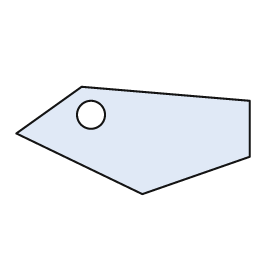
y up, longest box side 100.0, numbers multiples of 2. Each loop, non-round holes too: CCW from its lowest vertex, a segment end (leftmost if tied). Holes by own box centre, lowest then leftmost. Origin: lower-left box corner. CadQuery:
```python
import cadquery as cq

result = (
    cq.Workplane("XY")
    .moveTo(54.0, 0.0)
    .lineTo(100.0, 16.0)
    .lineTo(100.0, 40.0)
    .lineTo(28.0, 46.0)
    .lineTo(0.0, 26.0)
    .close()
    .moveTo(32.0, 34.0)
    .circle(6.0)
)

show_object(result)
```